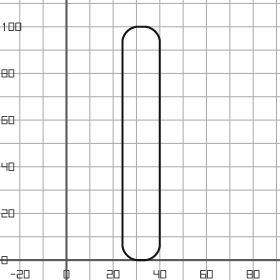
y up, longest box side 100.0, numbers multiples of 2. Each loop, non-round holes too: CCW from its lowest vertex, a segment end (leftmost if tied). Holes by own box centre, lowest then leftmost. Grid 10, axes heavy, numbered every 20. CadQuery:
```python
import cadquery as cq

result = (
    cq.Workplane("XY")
    .moveTo(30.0, 0.0)
    .lineTo(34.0, 0.0)
    .threePointArc((38.0, 2.0), (40.0, 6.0))
    .lineTo(40.0, 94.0)
    .threePointArc((38.0, 98.0), (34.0, 100.0))
    .lineTo(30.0, 100.0)
    .threePointArc((26.0, 98.0), (24.0, 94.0))
    .lineTo(24.0, 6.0)
    .threePointArc((26.0, 2.0), (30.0, 0.0))
    .close()
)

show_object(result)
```